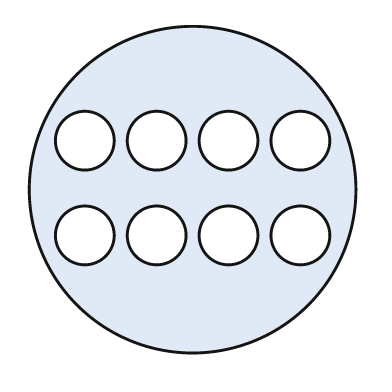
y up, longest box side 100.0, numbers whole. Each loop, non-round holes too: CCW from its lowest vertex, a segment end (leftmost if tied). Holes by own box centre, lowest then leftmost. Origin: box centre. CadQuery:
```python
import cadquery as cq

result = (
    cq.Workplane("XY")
    .moveTo(0.0, 0.0)
    .circle(50.0)
    .moveTo(-33.0, -14.0)
    .circle(9.0)
    .moveTo(-11.0, -14.0)
    .circle(9.0)
    .moveTo(11.0, -14.0)
    .circle(9.0)
    .moveTo(33.0, -14.0)
    .circle(9.0)
    .moveTo(-33.0, 15.0)
    .circle(9.0)
    .moveTo(-11.0, 15.0)
    .circle(9.0)
    .moveTo(11.0, 15.0)
    .circle(9.0)
    .moveTo(33.0, 15.0)
    .circle(9.0)
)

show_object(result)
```